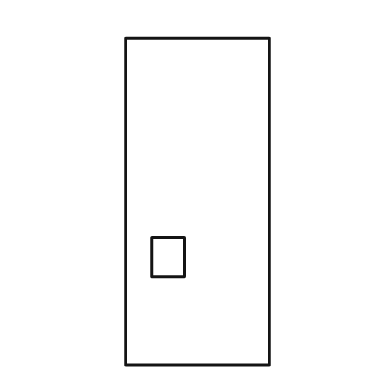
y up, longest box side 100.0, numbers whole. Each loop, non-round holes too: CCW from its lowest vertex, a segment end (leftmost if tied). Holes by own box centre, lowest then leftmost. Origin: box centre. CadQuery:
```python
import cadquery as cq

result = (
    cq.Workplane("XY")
    .moveTo(-22.0, -50.0)
    .lineTo(22.0, -50.0)
    .lineTo(22.0, 50.0)
    .lineTo(-22.0, 50.0)
    .close()
    .moveTo(-14.0, -23.0)
    .lineTo(-4.0, -23.0)
    .lineTo(-4.0, -11.0)
    .lineTo(-14.0, -11.0)
    .close()
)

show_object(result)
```